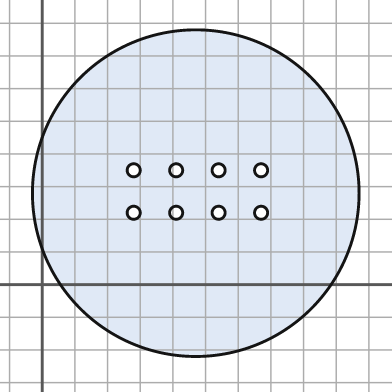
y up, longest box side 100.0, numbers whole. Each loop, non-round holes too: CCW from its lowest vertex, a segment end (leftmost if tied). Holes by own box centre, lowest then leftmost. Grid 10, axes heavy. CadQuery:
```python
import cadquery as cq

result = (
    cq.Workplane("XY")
    .moveTo(47.0, 28.0)
    .circle(50.0)
    .moveTo(28.0, 22.0)
    .circle(2.0)
    .moveTo(41.0, 22.0)
    .circle(2.0)
    .moveTo(54.0, 22.0)
    .circle(2.0)
    .moveTo(67.0, 22.0)
    .circle(2.0)
    .moveTo(28.0, 35.0)
    .circle(2.0)
    .moveTo(41.0, 35.0)
    .circle(2.0)
    .moveTo(54.0, 35.0)
    .circle(2.0)
    .moveTo(67.0, 35.0)
    .circle(2.0)
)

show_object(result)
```